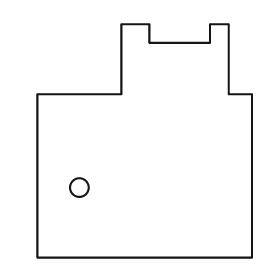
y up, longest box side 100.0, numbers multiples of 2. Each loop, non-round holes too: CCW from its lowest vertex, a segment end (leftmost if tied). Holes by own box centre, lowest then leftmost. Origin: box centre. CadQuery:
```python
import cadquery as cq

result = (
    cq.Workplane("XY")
    .moveTo(-46.0, -50.0)
    .lineTo(46.0, -50.0)
    .lineTo(46.0, 20.0)
    .lineTo(36.0, 20.0)
    .lineTo(36.0, 50.0)
    .lineTo(28.0, 50.0)
    .lineTo(28.0, 42.0)
    .lineTo(2.0, 42.0)
    .lineTo(2.0, 50.0)
    .lineTo(-10.0, 50.0)
    .lineTo(-10.0, 20.0)
    .lineTo(-46.0, 20.0)
    .close()
    .moveTo(-28.0, -20.0)
    .circle(4.0)
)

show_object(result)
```